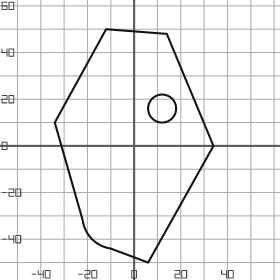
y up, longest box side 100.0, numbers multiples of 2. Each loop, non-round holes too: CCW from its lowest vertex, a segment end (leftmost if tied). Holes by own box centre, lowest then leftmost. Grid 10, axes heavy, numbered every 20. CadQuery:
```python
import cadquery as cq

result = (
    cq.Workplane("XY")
    .moveTo(6.0, -50.0)
    .lineTo(34.0, 0.0)
    .lineTo(14.0, 48.0)
    .lineTo(-12.0, 50.0)
    .lineTo(-34.0, 10.0)
    .lineTo(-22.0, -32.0)
    .threePointArc((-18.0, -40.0), (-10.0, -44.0))
    .close()
    .moveTo(12.0, 16.0)
    .circle(6.0)
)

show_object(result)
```